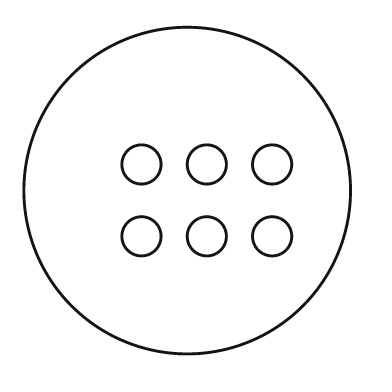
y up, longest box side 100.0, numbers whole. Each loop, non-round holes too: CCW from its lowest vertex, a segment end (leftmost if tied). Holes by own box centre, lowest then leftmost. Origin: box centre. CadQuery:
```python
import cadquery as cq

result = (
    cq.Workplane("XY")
    .moveTo(0.0, 0.0)
    .circle(50.0)
    .moveTo(-14.0, -14.0)
    .circle(6.0)
    .moveTo(6.0, -14.0)
    .circle(6.0)
    .moveTo(26.0, -14.0)
    .circle(6.0)
    .moveTo(-14.0, 8.0)
    .circle(6.0)
    .moveTo(6.0, 8.0)
    .circle(6.0)
    .moveTo(26.0, 8.0)
    .circle(6.0)
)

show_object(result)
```